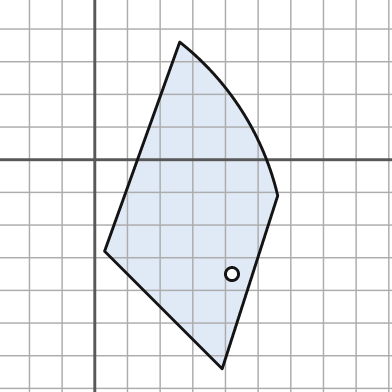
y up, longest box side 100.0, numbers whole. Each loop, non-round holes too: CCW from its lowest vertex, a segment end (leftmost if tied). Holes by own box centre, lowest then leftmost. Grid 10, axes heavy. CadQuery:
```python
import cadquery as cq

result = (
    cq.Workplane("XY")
    .moveTo(39.0, -64.0)
    .lineTo(56.0, -11.0)
    .threePointArc((45.0, 15.0), (26.0, 36.0))
    .lineTo(3.0, -28.0)
    .close()
    .moveTo(42.0, -35.0)
    .circle(2.0)
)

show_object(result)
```